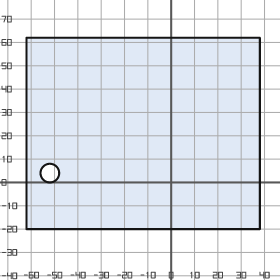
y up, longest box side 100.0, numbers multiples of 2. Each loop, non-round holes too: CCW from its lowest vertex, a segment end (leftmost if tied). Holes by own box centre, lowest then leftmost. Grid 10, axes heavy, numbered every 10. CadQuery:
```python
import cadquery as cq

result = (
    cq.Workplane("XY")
    .moveTo(-62.0, -20.0)
    .lineTo(38.0, -20.0)
    .lineTo(38.0, 62.0)
    .lineTo(-62.0, 62.0)
    .close()
    .moveTo(-52.0, 4.0)
    .circle(4.0)
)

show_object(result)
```